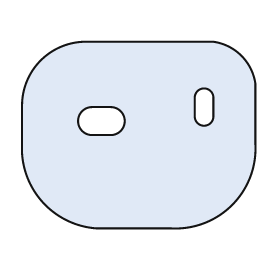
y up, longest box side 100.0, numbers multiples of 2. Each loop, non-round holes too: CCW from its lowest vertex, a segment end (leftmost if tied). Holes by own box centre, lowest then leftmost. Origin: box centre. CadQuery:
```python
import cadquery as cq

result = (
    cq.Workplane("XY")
    .moveTo(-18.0, -40.0)
    .lineTo(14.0, -40.0)
    .threePointArc((40.0, -30.0), (50.0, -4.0))
    .lineTo(50.0, 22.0)
    .threePointArc((44.0, 34.0), (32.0, 40.0))
    .lineTo(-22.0, 40.0)
    .threePointArc((-42.0, 32.0), (-50.0, 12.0))
    .lineTo(-50.0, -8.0)
    .threePointArc((-40.0, -30.0), (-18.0, -40.0))
    .close()
    .moveTo(-20.0, 0.0)
    .lineTo(-12.0, 0.0)
    .threePointArc((-6.0, 6.0), (-12.0, 12.0))
    .lineTo(-20.0, 12.0)
    .threePointArc((-26.0, 6.0), (-20.0, 0.0))
    .close()
    .moveTo(24.0, 8.0)
    .threePointArc((28.0, 4.0), (32.0, 8.0))
    .lineTo(32.0, 16.0)
    .threePointArc((28.0, 20.0), (24.0, 16.0))
    .close()
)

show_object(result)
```